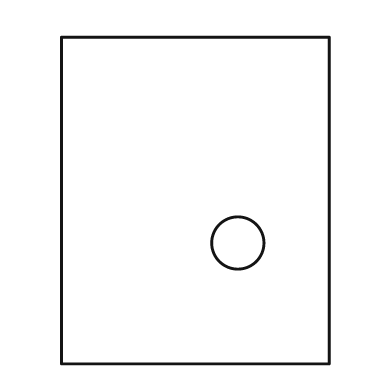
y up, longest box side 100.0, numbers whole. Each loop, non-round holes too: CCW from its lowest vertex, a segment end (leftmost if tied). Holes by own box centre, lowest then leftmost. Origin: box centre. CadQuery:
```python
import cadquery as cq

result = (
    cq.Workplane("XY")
    .moveTo(-41.0, -50.0)
    .lineTo(41.0, -50.0)
    .lineTo(41.0, 50.0)
    .lineTo(-41.0, 50.0)
    .close()
    .moveTo(13.0, -13.0)
    .circle(8.0)
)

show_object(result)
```